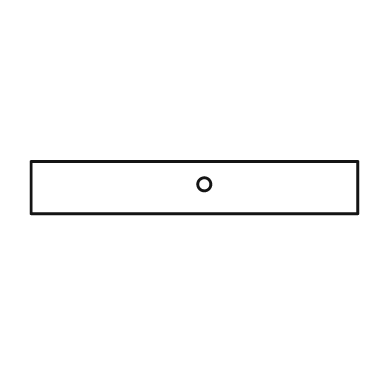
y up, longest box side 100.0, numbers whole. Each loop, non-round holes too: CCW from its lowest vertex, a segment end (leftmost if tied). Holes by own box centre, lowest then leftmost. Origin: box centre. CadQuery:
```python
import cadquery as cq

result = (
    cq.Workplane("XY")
    .moveTo(-50.0, -8.0)
    .lineTo(50.0, -8.0)
    .lineTo(50.0, 8.0)
    .lineTo(-50.0, 8.0)
    .close()
    .moveTo(3.0, 1.0)
    .circle(2.0)
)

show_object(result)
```